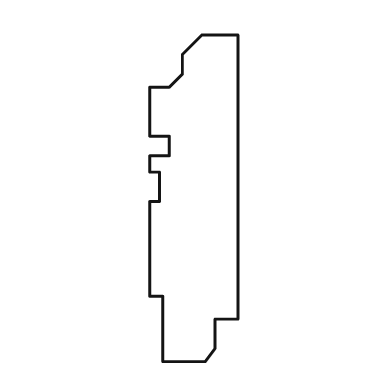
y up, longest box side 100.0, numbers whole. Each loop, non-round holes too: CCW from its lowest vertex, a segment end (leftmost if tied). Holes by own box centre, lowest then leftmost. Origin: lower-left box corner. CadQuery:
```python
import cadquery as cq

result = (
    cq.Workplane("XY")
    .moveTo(4.0, 0.0)
    .lineTo(17.0, 0.0)
    .lineTo(20.0, 4.0)
    .lineTo(20.0, 13.0)
    .lineTo(27.0, 13.0)
    .lineTo(27.0, 100.0)
    .lineTo(16.0, 100.0)
    .lineTo(10.0, 94.0)
    .lineTo(10.0, 88.0)
    .lineTo(6.0, 84.0)
    .lineTo(0.0, 84.0)
    .lineTo(0.0, 69.0)
    .lineTo(6.0, 69.0)
    .lineTo(6.0, 63.0)
    .lineTo(0.0, 63.0)
    .lineTo(0.0, 58.0)
    .lineTo(3.0, 58.0)
    .lineTo(3.0, 49.0)
    .lineTo(0.0, 49.0)
    .lineTo(0.0, 20.0)
    .lineTo(4.0, 20.0)
    .close()
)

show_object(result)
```